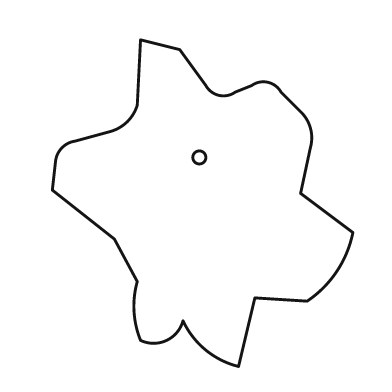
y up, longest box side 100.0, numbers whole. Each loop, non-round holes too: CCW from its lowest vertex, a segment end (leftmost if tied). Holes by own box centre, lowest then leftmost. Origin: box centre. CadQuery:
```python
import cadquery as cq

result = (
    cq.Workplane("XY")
    .moveTo(11.0, -50.0)
    .lineTo(16.0, -29.0)
    .lineTo(32.0, -30.0)
    .threePointArc((41.0, -21.0), (46.0, -9.0))
    .lineTo(30.0, 3.0)
    .lineTo(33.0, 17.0)
    .threePointArc((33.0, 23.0), (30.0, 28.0))
    .lineTo(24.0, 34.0)
    .threePointArc((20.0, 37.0), (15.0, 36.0))
    .lineTo(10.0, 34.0)
    .threePointArc((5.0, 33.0), (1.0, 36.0))
    .lineTo(-7.0, 47.0)
    .lineTo(-19.0, 50.0)
    .lineTo(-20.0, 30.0)
    .threePointArc((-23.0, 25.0), (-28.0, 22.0))
    .lineTo(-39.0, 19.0)
    .threePointArc((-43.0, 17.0), (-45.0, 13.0))
    .lineTo(-46.0, 4.0)
    .lineTo(-27.0, -11.0)
    .lineTo(-20.0, -24.0)
    .threePointArc((-21.0, -33.0), (-19.0, -42.0))
    .threePointArc((-11.0, -42.0), (-6.0, -36.0))
    .threePointArc((1.0, -45.0), (11.0, -50.0))
    .close()
    .moveTo(-1.0, 14.0)
    .circle(2.0)
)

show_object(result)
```